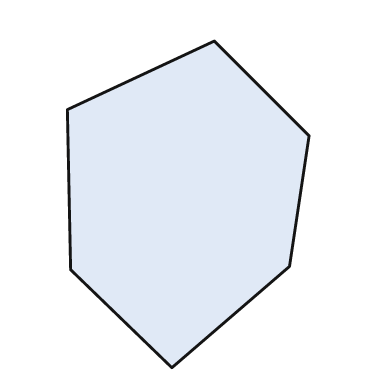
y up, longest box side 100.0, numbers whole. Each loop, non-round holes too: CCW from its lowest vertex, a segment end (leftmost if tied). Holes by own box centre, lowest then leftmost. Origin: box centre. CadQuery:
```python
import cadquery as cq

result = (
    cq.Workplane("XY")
    .moveTo(-5.0, -50.0)
    .lineTo(31.0, -19.0)
    .lineTo(37.0, 21.0)
    .lineTo(8.0, 50.0)
    .lineTo(-37.0, 29.0)
    .lineTo(-36.0, -20.0)
    .close()
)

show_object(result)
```